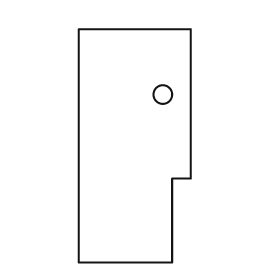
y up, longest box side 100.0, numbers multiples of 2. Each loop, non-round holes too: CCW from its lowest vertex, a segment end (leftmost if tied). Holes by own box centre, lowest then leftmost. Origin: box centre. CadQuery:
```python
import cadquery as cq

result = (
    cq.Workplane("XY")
    .moveTo(-24.0, -50.0)
    .lineTo(16.0, -50.0)
    .lineTo(16.0, -14.0)
    .lineTo(24.0, -14.0)
    .lineTo(24.0, 50.0)
    .lineTo(-24.0, 50.0)
    .close()
    .moveTo(12.0, 22.0)
    .circle(4.0)
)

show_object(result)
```